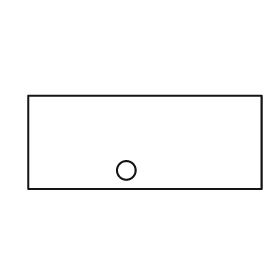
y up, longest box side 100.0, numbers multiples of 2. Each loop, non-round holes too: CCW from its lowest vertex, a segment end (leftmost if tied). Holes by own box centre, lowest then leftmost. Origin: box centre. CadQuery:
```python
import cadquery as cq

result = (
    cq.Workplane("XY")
    .moveTo(-50.0, -20.0)
    .lineTo(50.0, -20.0)
    .lineTo(50.0, 20.0)
    .lineTo(-50.0, 20.0)
    .close()
    .moveTo(-8.0, -12.0)
    .circle(4.0)
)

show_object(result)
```